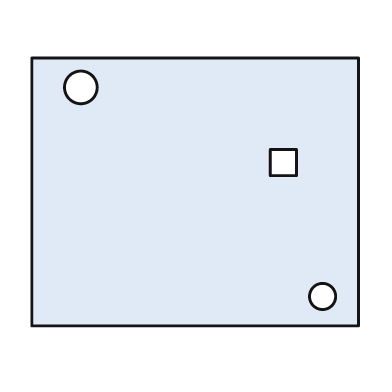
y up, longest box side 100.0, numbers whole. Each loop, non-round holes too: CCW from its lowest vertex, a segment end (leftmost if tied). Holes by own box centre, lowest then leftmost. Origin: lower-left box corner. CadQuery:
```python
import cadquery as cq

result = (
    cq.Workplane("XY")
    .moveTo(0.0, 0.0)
    .lineTo(100.0, 0.0)
    .lineTo(100.0, 82.0)
    .lineTo(0.0, 82.0)
    .close()
    .moveTo(89.0, 9.0)
    .circle(4.0)
    .moveTo(73.0, 46.0)
    .lineTo(81.0, 46.0)
    .lineTo(81.0, 54.0)
    .lineTo(73.0, 54.0)
    .close()
    .moveTo(15.0, 73.0)
    .circle(5.0)
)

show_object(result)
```